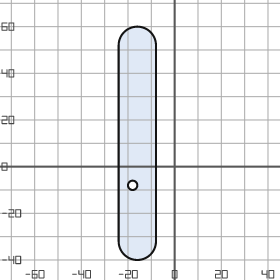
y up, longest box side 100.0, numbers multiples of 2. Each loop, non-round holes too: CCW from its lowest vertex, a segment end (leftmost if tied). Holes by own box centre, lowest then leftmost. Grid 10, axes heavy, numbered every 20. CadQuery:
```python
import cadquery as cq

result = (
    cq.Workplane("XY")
    .moveTo(-24.0, -32.0)
    .threePointArc((-16.0, -40.0), (-8.0, -32.0))
    .lineTo(-8.0, 52.0)
    .threePointArc((-16.0, 60.0), (-24.0, 52.0))
    .close()
    .moveTo(-18.0, -8.0)
    .circle(2.0)
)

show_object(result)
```